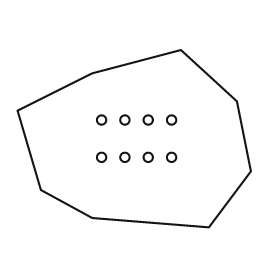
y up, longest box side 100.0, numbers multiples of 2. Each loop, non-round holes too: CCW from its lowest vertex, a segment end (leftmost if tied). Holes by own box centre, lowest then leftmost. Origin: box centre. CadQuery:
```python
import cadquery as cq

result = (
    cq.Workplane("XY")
    .moveTo(32.0, -38.0)
    .lineTo(50.0, -14.0)
    .lineTo(44.0, 16.0)
    .lineTo(20.0, 38.0)
    .lineTo(-18.0, 28.0)
    .lineTo(-50.0, 12.0)
    .lineTo(-40.0, -22.0)
    .lineTo(-18.0, -34.0)
    .close()
    .moveTo(-14.0, -8.0)
    .circle(2.0)
    .moveTo(-4.0, -8.0)
    .circle(2.0)
    .moveTo(6.0, -8.0)
    .circle(2.0)
    .moveTo(16.0, -8.0)
    .circle(2.0)
    .moveTo(-14.0, 8.0)
    .circle(2.0)
    .moveTo(-4.0, 8.0)
    .circle(2.0)
    .moveTo(6.0, 8.0)
    .circle(2.0)
    .moveTo(16.0, 8.0)
    .circle(2.0)
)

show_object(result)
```